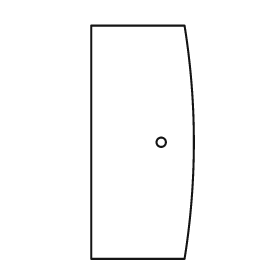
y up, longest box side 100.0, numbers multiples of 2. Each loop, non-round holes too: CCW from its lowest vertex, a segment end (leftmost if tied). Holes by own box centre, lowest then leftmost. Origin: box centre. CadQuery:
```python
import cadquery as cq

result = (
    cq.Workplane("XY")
    .moveTo(-22.0, -50.0)
    .lineTo(18.0, -50.0)
    .threePointArc((22.0, 0.0), (18.0, 50.0))
    .lineTo(-22.0, 50.0)
    .close()
    .moveTo(8.0, 0.0)
    .circle(2.0)
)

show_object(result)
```